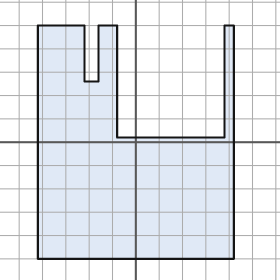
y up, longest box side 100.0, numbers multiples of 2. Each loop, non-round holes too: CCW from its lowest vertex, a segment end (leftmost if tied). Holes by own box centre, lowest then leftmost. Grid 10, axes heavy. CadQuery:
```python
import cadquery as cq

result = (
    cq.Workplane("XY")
    .moveTo(-42.0, -50.0)
    .lineTo(42.0, -50.0)
    .lineTo(42.0, 50.0)
    .lineTo(38.0, 50.0)
    .lineTo(38.0, 2.0)
    .lineTo(-8.0, 2.0)
    .lineTo(-8.0, 50.0)
    .lineTo(-16.0, 50.0)
    .lineTo(-16.0, 26.0)
    .lineTo(-22.0, 26.0)
    .lineTo(-22.0, 50.0)
    .lineTo(-42.0, 50.0)
    .close()
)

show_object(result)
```